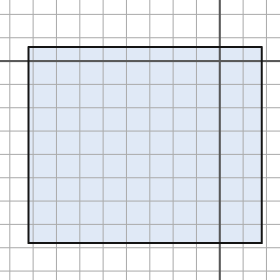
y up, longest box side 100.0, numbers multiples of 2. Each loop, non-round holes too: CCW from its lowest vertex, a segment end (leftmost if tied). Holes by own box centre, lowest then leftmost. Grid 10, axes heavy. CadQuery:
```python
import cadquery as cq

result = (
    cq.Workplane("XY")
    .moveTo(-82.0, -78.0)
    .lineTo(18.0, -78.0)
    .lineTo(18.0, 6.0)
    .lineTo(-82.0, 6.0)
    .close()
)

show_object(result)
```